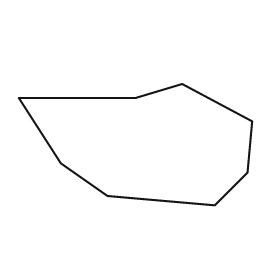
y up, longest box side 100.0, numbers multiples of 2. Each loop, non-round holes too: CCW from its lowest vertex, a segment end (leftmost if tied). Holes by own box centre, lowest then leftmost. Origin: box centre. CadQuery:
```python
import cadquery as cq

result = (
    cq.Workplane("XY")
    .moveTo(34.0, -26.0)
    .lineTo(48.0, -12.0)
    .lineTo(50.0, 10.0)
    .lineTo(20.0, 26.0)
    .lineTo(0.0, 20.0)
    .lineTo(-50.0, 20.0)
    .lineTo(-32.0, -8.0)
    .lineTo(-12.0, -22.0)
    .close()
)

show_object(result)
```